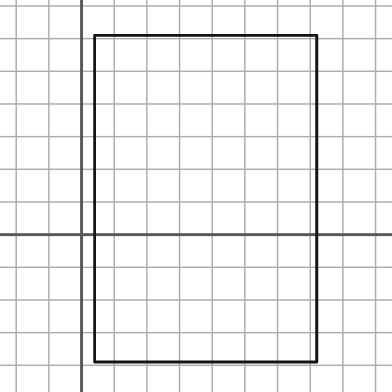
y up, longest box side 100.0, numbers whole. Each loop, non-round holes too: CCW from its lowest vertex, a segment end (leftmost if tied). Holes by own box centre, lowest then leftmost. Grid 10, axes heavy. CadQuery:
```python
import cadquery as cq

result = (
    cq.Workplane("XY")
    .moveTo(4.0, -39.0)
    .lineTo(72.0, -39.0)
    .lineTo(72.0, 61.0)
    .lineTo(4.0, 61.0)
    .close()
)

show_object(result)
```